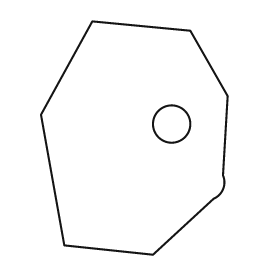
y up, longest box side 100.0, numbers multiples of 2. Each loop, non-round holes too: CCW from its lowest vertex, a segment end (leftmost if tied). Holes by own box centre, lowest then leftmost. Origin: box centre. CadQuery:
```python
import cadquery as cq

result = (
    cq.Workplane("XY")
    .moveTo(8.0, -50.0)
    .lineTo(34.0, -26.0)
    .threePointArc((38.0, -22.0), (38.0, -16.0))
    .lineTo(40.0, 18.0)
    .lineTo(24.0, 46.0)
    .lineTo(-18.0, 50.0)
    .lineTo(-40.0, 10.0)
    .lineTo(-30.0, -46.0)
    .close()
    .moveTo(16.0, 6.0)
    .circle(8.0)
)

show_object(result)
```